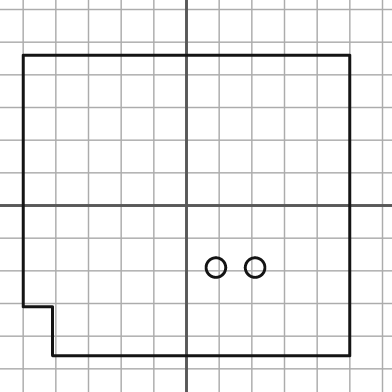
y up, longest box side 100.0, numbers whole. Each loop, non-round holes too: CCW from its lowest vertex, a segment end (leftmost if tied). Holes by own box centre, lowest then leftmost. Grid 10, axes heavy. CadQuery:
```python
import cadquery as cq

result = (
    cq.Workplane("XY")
    .moveTo(-41.0, -46.0)
    .lineTo(50.0, -46.0)
    .lineTo(50.0, 46.0)
    .lineTo(-50.0, 46.0)
    .lineTo(-50.0, -31.0)
    .lineTo(-41.0, -31.0)
    .close()
    .moveTo(9.0, -19.0)
    .circle(3.0)
    .moveTo(21.0, -19.0)
    .circle(3.0)
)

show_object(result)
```